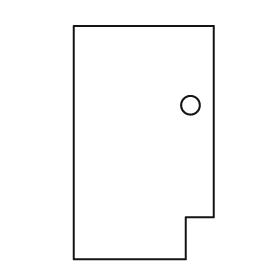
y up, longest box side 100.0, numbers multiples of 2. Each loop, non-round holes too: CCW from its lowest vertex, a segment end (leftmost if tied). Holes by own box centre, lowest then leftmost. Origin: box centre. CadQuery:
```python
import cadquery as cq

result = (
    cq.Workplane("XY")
    .moveTo(-30.0, -50.0)
    .lineTo(18.0, -50.0)
    .lineTo(18.0, -32.0)
    .lineTo(30.0, -32.0)
    .lineTo(30.0, 50.0)
    .lineTo(-30.0, 50.0)
    .close()
    .moveTo(20.0, 16.0)
    .circle(4.0)
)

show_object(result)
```